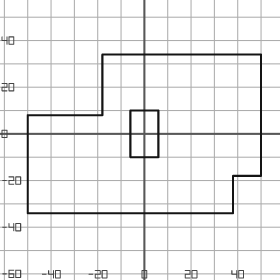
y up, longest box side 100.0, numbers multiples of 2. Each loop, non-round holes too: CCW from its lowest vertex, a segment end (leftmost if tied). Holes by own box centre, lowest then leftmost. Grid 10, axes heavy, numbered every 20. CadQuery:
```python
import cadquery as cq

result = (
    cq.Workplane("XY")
    .moveTo(-50.0, -34.0)
    .lineTo(38.0, -34.0)
    .lineTo(38.0, -18.0)
    .lineTo(50.0, -18.0)
    .lineTo(50.0, 34.0)
    .lineTo(-18.0, 34.0)
    .lineTo(-18.0, 8.0)
    .lineTo(-50.0, 8.0)
    .close()
    .moveTo(-6.0, -10.0)
    .lineTo(6.0, -10.0)
    .lineTo(6.0, 10.0)
    .lineTo(-6.0, 10.0)
    .close()
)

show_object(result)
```